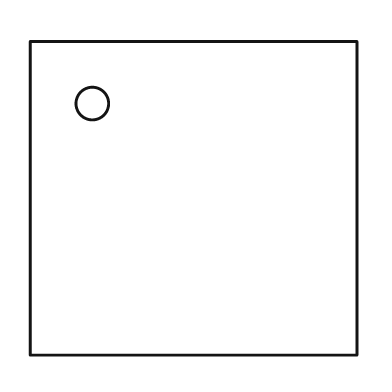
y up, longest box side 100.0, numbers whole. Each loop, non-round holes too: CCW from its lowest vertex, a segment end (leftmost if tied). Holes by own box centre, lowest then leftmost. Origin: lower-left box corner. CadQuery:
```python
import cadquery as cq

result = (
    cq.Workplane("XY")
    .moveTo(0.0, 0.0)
    .lineTo(100.0, 0.0)
    .lineTo(100.0, 96.0)
    .lineTo(0.0, 96.0)
    .close()
    .moveTo(19.0, 77.0)
    .circle(5.0)
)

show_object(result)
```